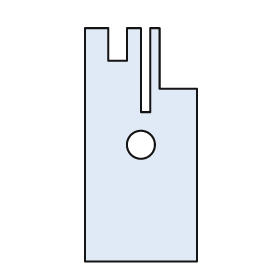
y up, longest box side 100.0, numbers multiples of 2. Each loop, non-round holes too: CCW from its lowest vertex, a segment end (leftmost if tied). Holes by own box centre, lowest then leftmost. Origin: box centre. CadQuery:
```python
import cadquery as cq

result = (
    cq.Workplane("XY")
    .moveTo(-24.0, -50.0)
    .lineTo(24.0, -50.0)
    .lineTo(24.0, 24.0)
    .lineTo(8.0, 24.0)
    .lineTo(8.0, 50.0)
    .lineTo(4.0, 50.0)
    .lineTo(4.0, 14.0)
    .lineTo(0.0, 14.0)
    .lineTo(0.0, 50.0)
    .lineTo(-6.0, 50.0)
    .lineTo(-6.0, 36.0)
    .lineTo(-14.0, 36.0)
    .lineTo(-14.0, 50.0)
    .lineTo(-24.0, 50.0)
    .close()
    .moveTo(0.0, 0.0)
    .circle(6.0)
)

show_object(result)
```